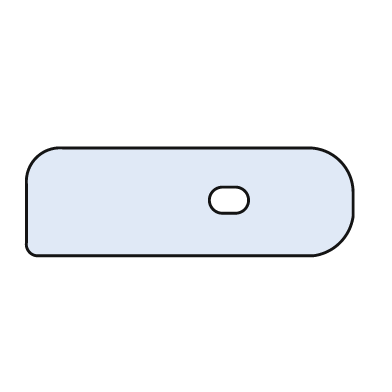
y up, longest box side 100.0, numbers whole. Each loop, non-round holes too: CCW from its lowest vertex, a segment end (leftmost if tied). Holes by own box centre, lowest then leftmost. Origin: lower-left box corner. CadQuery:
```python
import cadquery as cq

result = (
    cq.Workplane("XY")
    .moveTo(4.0, 0.0)
    .lineTo(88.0, 0.0)
    .threePointArc((96.0, 4.0), (100.0, 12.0))
    .lineTo(100.0, 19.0)
    .threePointArc((96.0, 29.0), (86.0, 33.0))
    .lineTo(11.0, 33.0)
    .threePointArc((3.0, 30.0), (0.0, 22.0))
    .lineTo(0.0, 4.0)
    .threePointArc((1.0, 1.0), (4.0, 0.0))
    .close()
    .moveTo(60.0, 13.0)
    .lineTo(64.0, 13.0)
    .threePointArc((68.0, 17.0), (64.0, 21.0))
    .lineTo(60.0, 21.0)
    .threePointArc((56.0, 17.0), (60.0, 13.0))
    .close()
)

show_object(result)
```